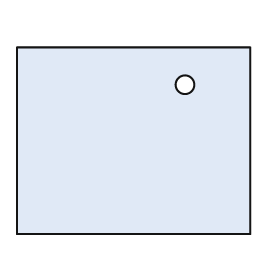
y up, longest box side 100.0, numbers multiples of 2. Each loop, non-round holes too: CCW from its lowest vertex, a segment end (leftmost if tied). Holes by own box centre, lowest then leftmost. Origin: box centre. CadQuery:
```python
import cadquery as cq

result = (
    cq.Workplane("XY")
    .moveTo(-50.0, -40.0)
    .lineTo(50.0, -40.0)
    .lineTo(50.0, 40.0)
    .lineTo(-50.0, 40.0)
    .close()
    .moveTo(22.0, 24.0)
    .circle(4.0)
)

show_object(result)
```